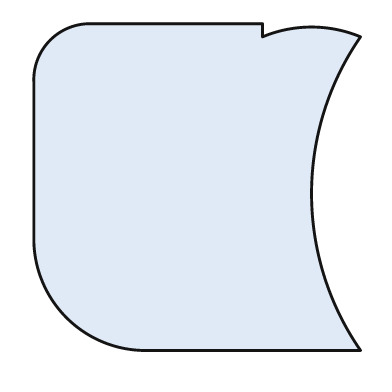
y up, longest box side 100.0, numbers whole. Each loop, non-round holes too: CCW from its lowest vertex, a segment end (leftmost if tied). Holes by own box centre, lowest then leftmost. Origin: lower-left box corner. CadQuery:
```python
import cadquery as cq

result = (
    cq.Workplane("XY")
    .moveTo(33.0, 0.0)
    .lineTo(100.0, 0.0)
    .threePointArc((85.0, 48.0), (100.0, 96.0))
    .threePointArc((85.0, 99.0), (70.0, 96.0))
    .lineTo(70.0, 100.0)
    .lineTo(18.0, 100.0)
    .threePointArc((5.0, 95.0), (0.0, 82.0))
    .lineTo(0.0, 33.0)
    .threePointArc((10.0, 10.0), (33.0, 0.0))
    .close()
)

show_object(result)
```